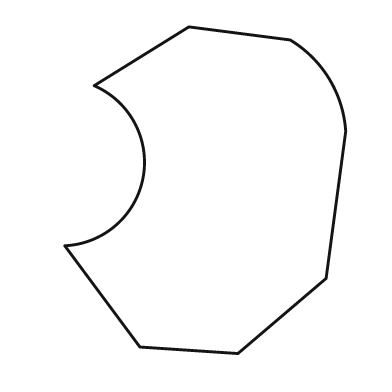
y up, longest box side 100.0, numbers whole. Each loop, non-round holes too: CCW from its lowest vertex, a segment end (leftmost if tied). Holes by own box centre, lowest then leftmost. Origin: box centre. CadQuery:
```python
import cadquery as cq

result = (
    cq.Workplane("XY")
    .moveTo(10.0, -50.0)
    .lineTo(37.0, -27.0)
    .lineTo(43.0, 18.0)
    .threePointArc((38.0, 34.0), (26.0, 46.0))
    .lineTo(-5.0, 50.0)
    .lineTo(-34.0, 32.0)
    .threePointArc((-19.0, 4.0), (-43.0, -17.0))
    .lineTo(-20.0, -48.0)
    .close()
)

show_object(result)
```